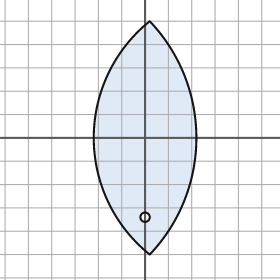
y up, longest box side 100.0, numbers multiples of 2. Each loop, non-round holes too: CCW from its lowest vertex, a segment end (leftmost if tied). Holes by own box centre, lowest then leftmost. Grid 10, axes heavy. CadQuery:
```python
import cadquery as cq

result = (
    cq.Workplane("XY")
    .moveTo(2.0, -50.0)
    .threePointArc((22.0, 0.0), (2.0, 50.0))
    .threePointArc((-22.0, 0.0), (2.0, -50.0))
    .close()
    .moveTo(0.0, -34.0)
    .circle(2.0)
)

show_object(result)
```